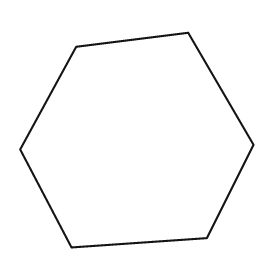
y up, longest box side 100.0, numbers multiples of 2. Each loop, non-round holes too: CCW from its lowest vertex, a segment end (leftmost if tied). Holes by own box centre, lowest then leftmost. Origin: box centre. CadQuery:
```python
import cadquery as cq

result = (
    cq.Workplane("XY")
    .moveTo(-28.0, -46.0)
    .lineTo(30.0, -42.0)
    .lineTo(50.0, -2.0)
    .lineTo(22.0, 46.0)
    .lineTo(-26.0, 40.0)
    .lineTo(-50.0, -4.0)
    .close()
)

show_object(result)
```